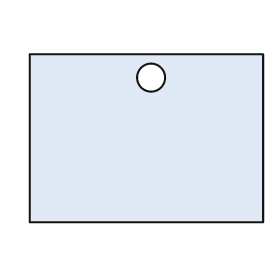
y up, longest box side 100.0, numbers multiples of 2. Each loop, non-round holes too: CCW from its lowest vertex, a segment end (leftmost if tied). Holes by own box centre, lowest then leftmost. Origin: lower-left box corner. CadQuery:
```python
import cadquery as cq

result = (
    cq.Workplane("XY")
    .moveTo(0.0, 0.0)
    .lineTo(100.0, 0.0)
    .lineTo(100.0, 72.0)
    .lineTo(0.0, 72.0)
    .close()
    .moveTo(52.0, 62.0)
    .circle(6.0)
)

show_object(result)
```